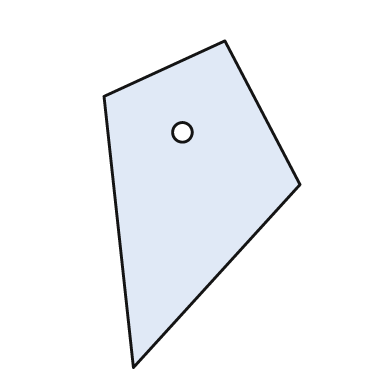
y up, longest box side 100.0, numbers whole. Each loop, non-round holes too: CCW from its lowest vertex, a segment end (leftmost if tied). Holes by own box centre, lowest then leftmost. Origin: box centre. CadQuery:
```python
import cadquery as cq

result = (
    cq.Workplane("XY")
    .moveTo(-21.0, -50.0)
    .lineTo(30.0, 6.0)
    .lineTo(7.0, 50.0)
    .lineTo(-30.0, 33.0)
    .close()
    .moveTo(-6.0, 22.0)
    .circle(3.0)
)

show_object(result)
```